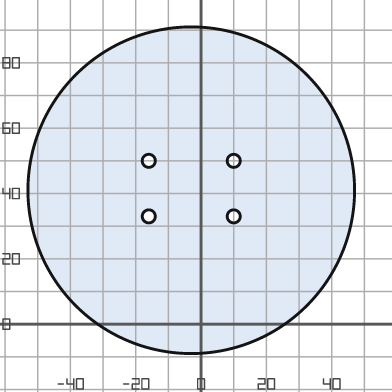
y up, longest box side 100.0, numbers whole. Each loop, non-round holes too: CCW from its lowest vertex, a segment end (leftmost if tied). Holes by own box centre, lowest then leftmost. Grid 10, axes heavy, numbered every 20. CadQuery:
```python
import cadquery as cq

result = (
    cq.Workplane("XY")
    .moveTo(-3.0, 41.0)
    .circle(50.0)
    .moveTo(-16.0, 33.0)
    .circle(2.0)
    .moveTo(10.0, 33.0)
    .circle(2.0)
    .moveTo(-16.0, 50.0)
    .circle(2.0)
    .moveTo(10.0, 50.0)
    .circle(2.0)
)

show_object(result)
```